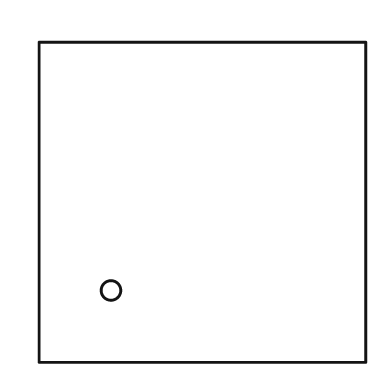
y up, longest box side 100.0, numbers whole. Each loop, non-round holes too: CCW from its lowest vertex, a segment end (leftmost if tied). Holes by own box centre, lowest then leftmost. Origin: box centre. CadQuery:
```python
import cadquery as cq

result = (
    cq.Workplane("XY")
    .moveTo(-50.0, -49.0)
    .lineTo(50.0, -49.0)
    .lineTo(50.0, 49.0)
    .lineTo(-50.0, 49.0)
    .close()
    .moveTo(-28.0, -27.0)
    .circle(3.0)
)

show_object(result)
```